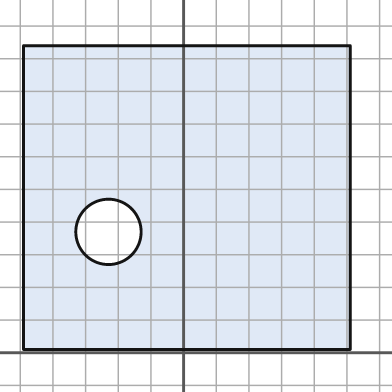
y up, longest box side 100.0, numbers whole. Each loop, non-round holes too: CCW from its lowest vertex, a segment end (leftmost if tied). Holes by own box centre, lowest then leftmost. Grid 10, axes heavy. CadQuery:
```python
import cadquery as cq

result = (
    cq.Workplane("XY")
    .moveTo(-49.0, 1.0)
    .lineTo(51.0, 1.0)
    .lineTo(51.0, 94.0)
    .lineTo(-49.0, 94.0)
    .close()
    .moveTo(-23.0, 37.0)
    .circle(10.0)
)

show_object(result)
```